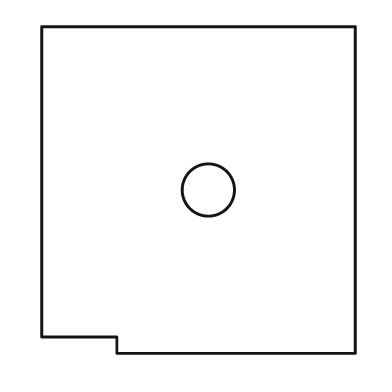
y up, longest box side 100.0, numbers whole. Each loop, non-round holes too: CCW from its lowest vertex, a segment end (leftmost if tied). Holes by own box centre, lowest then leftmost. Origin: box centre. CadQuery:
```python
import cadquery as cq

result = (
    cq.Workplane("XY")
    .moveTo(-25.0, -50.0)
    .lineTo(48.0, -50.0)
    .lineTo(48.0, 50.0)
    .lineTo(-48.0, 50.0)
    .lineTo(-48.0, -45.0)
    .lineTo(-25.0, -45.0)
    .close()
    .moveTo(3.0, 0.0)
    .circle(8.0)
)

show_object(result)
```